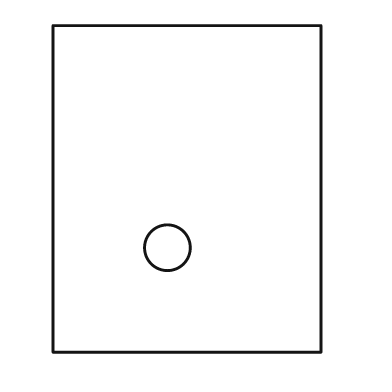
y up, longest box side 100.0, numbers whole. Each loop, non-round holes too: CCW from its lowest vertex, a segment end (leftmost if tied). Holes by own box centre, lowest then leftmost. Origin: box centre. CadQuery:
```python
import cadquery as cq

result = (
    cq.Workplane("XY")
    .moveTo(-41.0, -50.0)
    .lineTo(41.0, -50.0)
    .lineTo(41.0, 50.0)
    .lineTo(-41.0, 50.0)
    .close()
    .moveTo(-6.0, -18.0)
    .circle(7.0)
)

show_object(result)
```